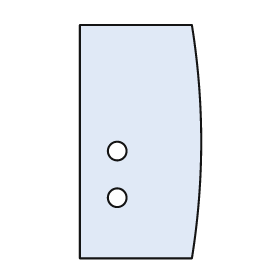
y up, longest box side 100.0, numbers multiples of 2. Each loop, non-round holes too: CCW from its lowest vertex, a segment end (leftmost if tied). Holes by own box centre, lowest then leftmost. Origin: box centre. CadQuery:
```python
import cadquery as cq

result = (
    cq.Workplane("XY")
    .moveTo(-26.0, -50.0)
    .lineTo(22.0, -50.0)
    .threePointArc((26.0, 0.0), (22.0, 50.0))
    .lineTo(-26.0, 50.0)
    .close()
    .moveTo(-10.0, -24.0)
    .circle(4.0)
    .moveTo(-10.0, -4.0)
    .circle(4.0)
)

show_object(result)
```